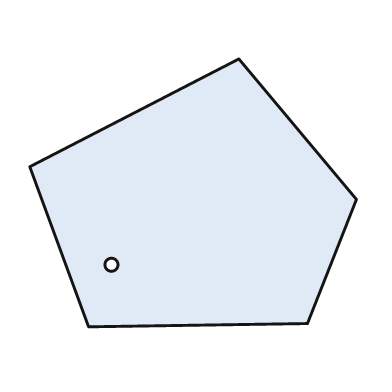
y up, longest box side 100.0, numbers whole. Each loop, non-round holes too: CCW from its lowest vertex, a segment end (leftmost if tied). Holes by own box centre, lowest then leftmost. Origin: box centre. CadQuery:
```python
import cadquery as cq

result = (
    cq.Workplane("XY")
    .moveTo(-32.0, -41.0)
    .lineTo(35.0, -40.0)
    .lineTo(50.0, -2.0)
    .lineTo(14.0, 41.0)
    .lineTo(-50.0, 8.0)
    .close()
    .moveTo(-25.0, -22.0)
    .circle(2.0)
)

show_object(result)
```